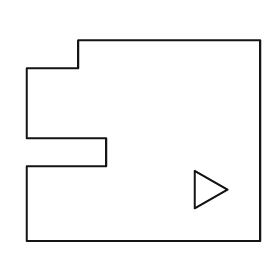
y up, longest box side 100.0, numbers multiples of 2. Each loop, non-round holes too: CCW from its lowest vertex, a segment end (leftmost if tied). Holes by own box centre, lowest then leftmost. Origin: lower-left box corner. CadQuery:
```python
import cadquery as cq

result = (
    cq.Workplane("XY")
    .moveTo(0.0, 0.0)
    .lineTo(100.0, 0.0)
    .lineTo(100.0, 86.0)
    .lineTo(22.0, 86.0)
    .lineTo(22.0, 74.0)
    .lineTo(0.0, 74.0)
    .lineTo(0.0, 44.0)
    .lineTo(34.0, 44.0)
    .lineTo(34.0, 32.0)
    .lineTo(0.0, 32.0)
    .close()
    .moveTo(72.0, 14.0)
    .lineTo(86.0, 22.0)
    .lineTo(72.0, 30.0)
    .close()
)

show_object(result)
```